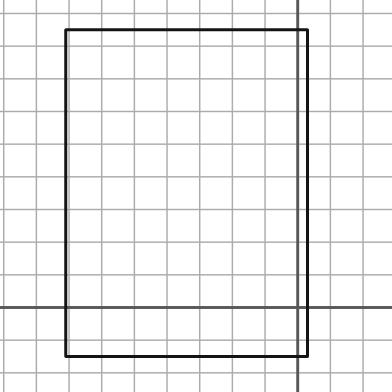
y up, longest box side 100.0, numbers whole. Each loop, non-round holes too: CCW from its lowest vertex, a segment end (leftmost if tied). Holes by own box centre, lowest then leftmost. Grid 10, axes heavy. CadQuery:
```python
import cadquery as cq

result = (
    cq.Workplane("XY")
    .moveTo(-71.0, -15.0)
    .lineTo(3.0, -15.0)
    .lineTo(3.0, 85.0)
    .lineTo(-71.0, 85.0)
    .close()
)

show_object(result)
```